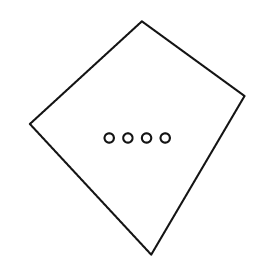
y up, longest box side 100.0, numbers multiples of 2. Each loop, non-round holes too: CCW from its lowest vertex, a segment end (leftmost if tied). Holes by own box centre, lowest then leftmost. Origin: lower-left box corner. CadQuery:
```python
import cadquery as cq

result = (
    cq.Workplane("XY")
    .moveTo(52.0, 0.0)
    .lineTo(92.0, 68.0)
    .lineTo(48.0, 100.0)
    .lineTo(0.0, 56.0)
    .close()
    .moveTo(34.0, 50.0)
    .circle(2.0)
    .moveTo(42.0, 50.0)
    .circle(2.0)
    .moveTo(50.0, 50.0)
    .circle(2.0)
    .moveTo(58.0, 50.0)
    .circle(2.0)
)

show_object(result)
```